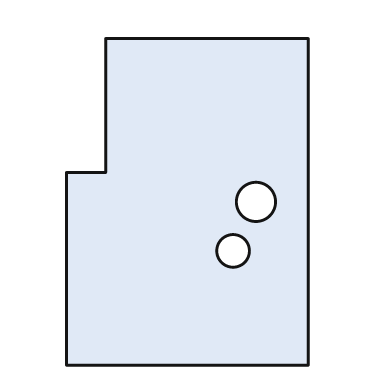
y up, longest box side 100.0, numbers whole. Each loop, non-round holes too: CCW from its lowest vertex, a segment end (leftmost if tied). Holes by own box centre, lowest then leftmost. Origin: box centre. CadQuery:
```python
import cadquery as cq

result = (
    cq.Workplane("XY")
    .moveTo(-37.0, -50.0)
    .lineTo(37.0, -50.0)
    .lineTo(37.0, 50.0)
    .lineTo(-25.0, 50.0)
    .lineTo(-25.0, 9.0)
    .lineTo(-37.0, 9.0)
    .close()
    .moveTo(14.0, -15.0)
    .circle(5.0)
    .moveTo(21.0, 0.0)
    .circle(6.0)
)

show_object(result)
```